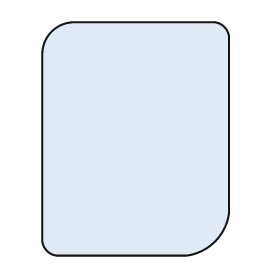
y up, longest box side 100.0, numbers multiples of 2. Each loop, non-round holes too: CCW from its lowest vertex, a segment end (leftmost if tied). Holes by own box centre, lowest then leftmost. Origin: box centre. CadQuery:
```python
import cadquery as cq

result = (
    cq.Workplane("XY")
    .moveTo(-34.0, -50.0)
    .lineTo(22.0, -50.0)
    .threePointArc((34.0, -44.0), (40.0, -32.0))
    .lineTo(40.0, 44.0)
    .threePointArc((38.0, 48.0), (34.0, 50.0))
    .lineTo(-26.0, 50.0)
    .threePointArc((-36.0, 46.0), (-40.0, 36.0))
    .lineTo(-40.0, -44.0)
    .threePointArc((-38.0, -48.0), (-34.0, -50.0))
    .close()
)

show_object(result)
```